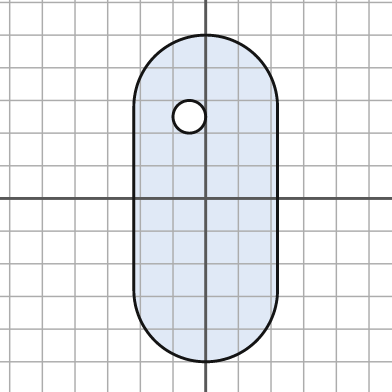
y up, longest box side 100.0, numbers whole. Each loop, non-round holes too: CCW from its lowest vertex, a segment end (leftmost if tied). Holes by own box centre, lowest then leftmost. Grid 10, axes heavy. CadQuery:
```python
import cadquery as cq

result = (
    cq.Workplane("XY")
    .moveTo(-22.0, -28.0)
    .threePointArc((0.0, -50.0), (22.0, -28.0))
    .lineTo(22.0, 28.0)
    .threePointArc((0.0, 50.0), (-22.0, 28.0))
    .close()
    .moveTo(-5.0, 25.0)
    .circle(5.0)
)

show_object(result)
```